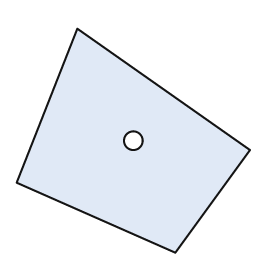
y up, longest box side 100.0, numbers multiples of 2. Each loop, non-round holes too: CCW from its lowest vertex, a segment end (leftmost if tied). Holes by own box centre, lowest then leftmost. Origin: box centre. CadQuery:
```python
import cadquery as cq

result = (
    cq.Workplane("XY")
    .moveTo(18.0, -48.0)
    .lineTo(50.0, -4.0)
    .lineTo(-24.0, 48.0)
    .lineTo(-50.0, -18.0)
    .close()
    .moveTo(0.0, 0.0)
    .circle(4.0)
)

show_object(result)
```